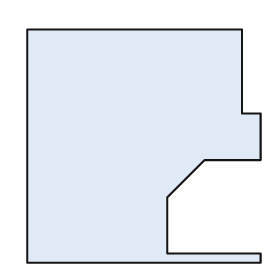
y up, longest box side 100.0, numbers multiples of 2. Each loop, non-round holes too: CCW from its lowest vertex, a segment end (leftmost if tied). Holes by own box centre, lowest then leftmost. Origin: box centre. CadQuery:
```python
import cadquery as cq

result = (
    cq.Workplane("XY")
    .moveTo(-50.0, -50.0)
    .lineTo(50.0, -50.0)
    .lineTo(50.0, -46.0)
    .lineTo(10.0, -46.0)
    .lineTo(10.0, -22.0)
    .lineTo(26.0, -6.0)
    .lineTo(50.0, -6.0)
    .lineTo(50.0, 14.0)
    .lineTo(42.0, 14.0)
    .lineTo(42.0, 50.0)
    .lineTo(-50.0, 50.0)
    .close()
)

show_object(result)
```